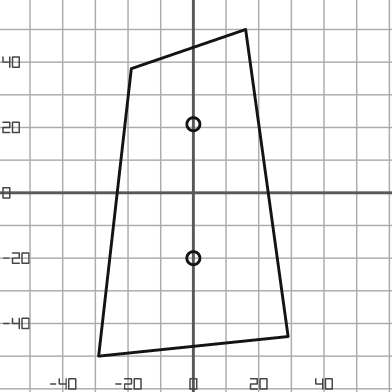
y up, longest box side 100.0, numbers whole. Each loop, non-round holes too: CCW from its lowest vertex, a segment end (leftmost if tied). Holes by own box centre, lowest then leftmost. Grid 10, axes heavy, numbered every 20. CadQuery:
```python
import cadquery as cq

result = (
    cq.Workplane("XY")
    .moveTo(-29.0, -50.0)
    .lineTo(29.0, -44.0)
    .lineTo(16.0, 50.0)
    .lineTo(-19.0, 38.0)
    .close()
    .moveTo(0.0, -20.0)
    .circle(2.0)
    .moveTo(0.0, 21.0)
    .circle(2.0)
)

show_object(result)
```